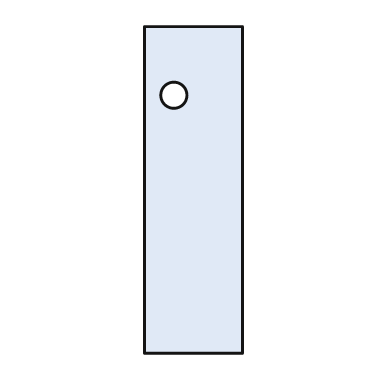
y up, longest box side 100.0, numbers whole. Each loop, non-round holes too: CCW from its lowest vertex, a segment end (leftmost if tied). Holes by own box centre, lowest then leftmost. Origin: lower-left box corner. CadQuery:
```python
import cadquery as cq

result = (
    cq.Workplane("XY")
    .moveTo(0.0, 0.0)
    .lineTo(30.0, 0.0)
    .lineTo(30.0, 100.0)
    .lineTo(0.0, 100.0)
    .close()
    .moveTo(9.0, 79.0)
    .circle(4.0)
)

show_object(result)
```